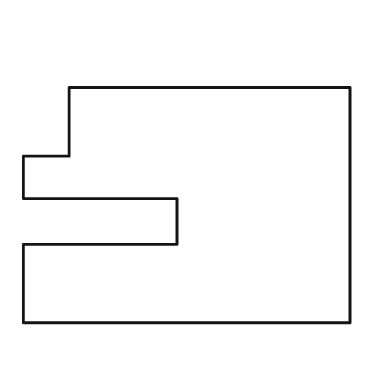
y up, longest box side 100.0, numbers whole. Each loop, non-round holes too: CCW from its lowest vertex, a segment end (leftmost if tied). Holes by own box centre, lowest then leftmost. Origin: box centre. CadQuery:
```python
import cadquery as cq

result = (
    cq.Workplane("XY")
    .moveTo(-50.0, -36.0)
    .lineTo(50.0, -36.0)
    .lineTo(50.0, 36.0)
    .lineTo(-36.0, 36.0)
    .lineTo(-36.0, 15.0)
    .lineTo(-50.0, 15.0)
    .lineTo(-50.0, 2.0)
    .lineTo(-3.0, 2.0)
    .lineTo(-3.0, -12.0)
    .lineTo(-50.0, -12.0)
    .close()
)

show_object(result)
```